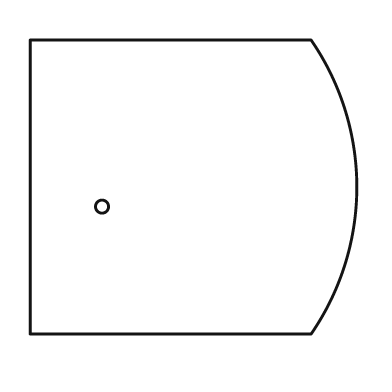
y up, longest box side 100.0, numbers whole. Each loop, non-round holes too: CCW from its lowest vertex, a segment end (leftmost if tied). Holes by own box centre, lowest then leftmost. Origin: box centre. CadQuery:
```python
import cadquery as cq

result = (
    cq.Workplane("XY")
    .moveTo(-50.0, -45.0)
    .lineTo(36.0, -45.0)
    .threePointArc((50.0, 0.0), (36.0, 45.0))
    .lineTo(-50.0, 45.0)
    .close()
    .moveTo(-28.0, -6.0)
    .circle(2.0)
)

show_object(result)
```